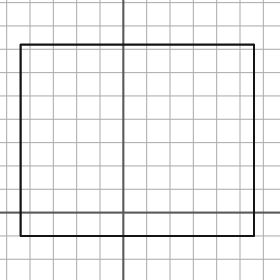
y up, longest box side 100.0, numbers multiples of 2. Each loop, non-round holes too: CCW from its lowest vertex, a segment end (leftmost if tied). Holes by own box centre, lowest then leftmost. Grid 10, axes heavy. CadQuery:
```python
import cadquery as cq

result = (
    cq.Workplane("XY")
    .moveTo(-44.0, -10.0)
    .lineTo(56.0, -10.0)
    .lineTo(56.0, 72.0)
    .lineTo(-44.0, 72.0)
    .close()
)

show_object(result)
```